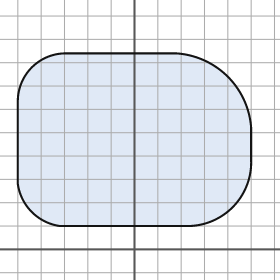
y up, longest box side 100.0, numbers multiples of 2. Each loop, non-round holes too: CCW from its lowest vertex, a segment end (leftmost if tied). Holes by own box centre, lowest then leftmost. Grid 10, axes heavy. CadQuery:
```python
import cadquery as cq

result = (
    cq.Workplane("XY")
    .moveTo(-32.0, 10.0)
    .lineTo(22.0, 10.0)
    .threePointArc((42.0, 18.0), (50.0, 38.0))
    .lineTo(50.0, 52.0)
    .threePointArc((40.0, 74.0), (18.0, 84.0))
    .lineTo(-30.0, 84.0)
    .threePointArc((-44.0, 78.0), (-50.0, 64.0))
    .lineTo(-50.0, 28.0)
    .threePointArc((-44.0, 16.0), (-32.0, 10.0))
    .close()
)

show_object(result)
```